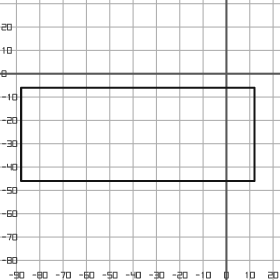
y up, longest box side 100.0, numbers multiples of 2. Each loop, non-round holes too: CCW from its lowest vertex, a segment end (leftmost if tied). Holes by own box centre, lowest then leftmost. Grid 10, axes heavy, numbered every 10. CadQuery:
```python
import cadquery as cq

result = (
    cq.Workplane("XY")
    .moveTo(-88.0, -46.0)
    .lineTo(12.0, -46.0)
    .lineTo(12.0, -6.0)
    .lineTo(-88.0, -6.0)
    .close()
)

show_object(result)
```